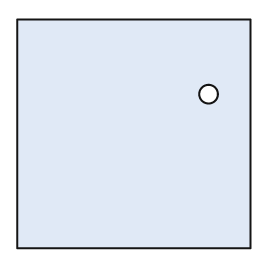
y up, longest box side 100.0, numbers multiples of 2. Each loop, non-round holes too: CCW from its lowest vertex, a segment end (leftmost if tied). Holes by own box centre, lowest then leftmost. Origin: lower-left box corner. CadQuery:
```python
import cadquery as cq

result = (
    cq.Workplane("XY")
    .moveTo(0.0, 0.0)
    .lineTo(100.0, 0.0)
    .lineTo(100.0, 98.0)
    .lineTo(0.0, 98.0)
    .close()
    .moveTo(82.0, 66.0)
    .circle(4.0)
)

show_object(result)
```